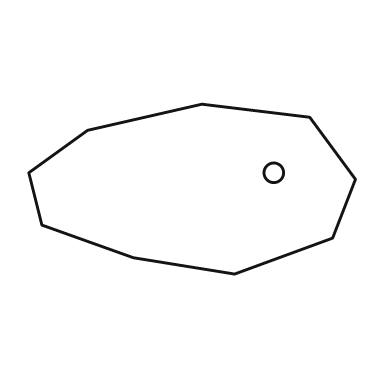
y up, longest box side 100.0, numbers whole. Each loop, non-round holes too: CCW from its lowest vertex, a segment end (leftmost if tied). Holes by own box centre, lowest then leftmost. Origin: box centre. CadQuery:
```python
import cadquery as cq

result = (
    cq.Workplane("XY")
    .moveTo(13.0, -26.0)
    .lineTo(43.0, -15.0)
    .lineTo(50.0, 3.0)
    .lineTo(36.0, 22.0)
    .lineTo(3.0, 26.0)
    .lineTo(-32.0, 18.0)
    .lineTo(-50.0, 5.0)
    .lineTo(-46.0, -11.0)
    .lineTo(-18.0, -21.0)
    .close()
    .moveTo(25.0, 5.0)
    .circle(3.0)
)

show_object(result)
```